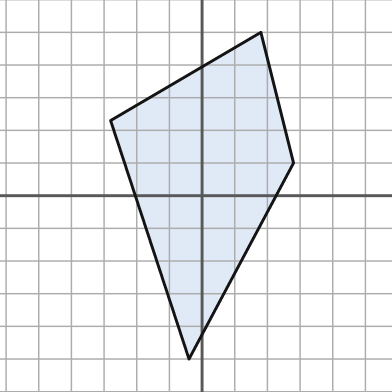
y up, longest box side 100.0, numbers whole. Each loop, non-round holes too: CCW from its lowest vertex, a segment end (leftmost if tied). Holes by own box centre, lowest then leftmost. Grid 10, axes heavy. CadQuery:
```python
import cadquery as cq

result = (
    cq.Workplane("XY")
    .moveTo(-4.0, -50.0)
    .lineTo(28.0, 10.0)
    .lineTo(18.0, 50.0)
    .lineTo(-28.0, 23.0)
    .close()
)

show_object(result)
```